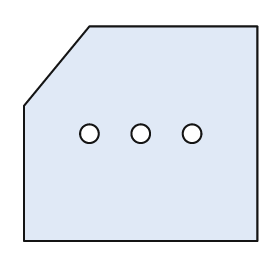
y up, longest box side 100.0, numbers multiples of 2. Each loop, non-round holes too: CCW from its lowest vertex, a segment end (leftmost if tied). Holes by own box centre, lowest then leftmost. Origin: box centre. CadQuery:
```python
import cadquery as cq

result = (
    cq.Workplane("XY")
    .moveTo(-50.0, -46.0)
    .lineTo(50.0, -46.0)
    .lineTo(50.0, 46.0)
    .lineTo(-22.0, 46.0)
    .lineTo(-50.0, 12.0)
    .close()
    .moveTo(-22.0, 0.0)
    .circle(4.0)
    .moveTo(0.0, 0.0)
    .circle(4.0)
    .moveTo(22.0, 0.0)
    .circle(4.0)
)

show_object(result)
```